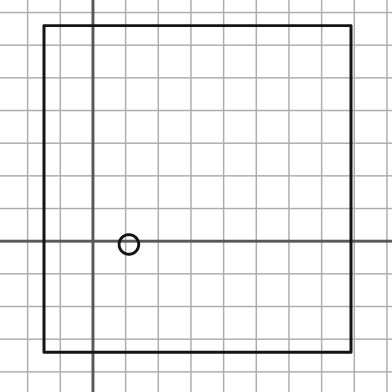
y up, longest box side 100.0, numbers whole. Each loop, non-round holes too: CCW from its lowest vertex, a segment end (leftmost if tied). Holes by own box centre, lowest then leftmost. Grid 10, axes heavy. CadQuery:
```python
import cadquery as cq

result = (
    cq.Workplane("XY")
    .moveTo(-15.0, -34.0)
    .lineTo(79.0, -34.0)
    .lineTo(79.0, 66.0)
    .lineTo(-15.0, 66.0)
    .close()
    .moveTo(11.0, -1.0)
    .circle(3.0)
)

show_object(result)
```